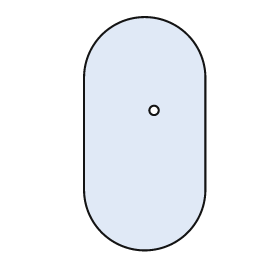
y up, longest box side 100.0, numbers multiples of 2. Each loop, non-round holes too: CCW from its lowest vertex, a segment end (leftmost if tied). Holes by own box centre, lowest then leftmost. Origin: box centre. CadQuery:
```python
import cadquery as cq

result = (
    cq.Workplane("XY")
    .moveTo(-26.0, -24.0)
    .threePointArc((0.0, -50.0), (26.0, -24.0))
    .lineTo(26.0, 24.0)
    .threePointArc((0.0, 50.0), (-26.0, 24.0))
    .close()
    .moveTo(4.0, 10.0)
    .circle(2.0)
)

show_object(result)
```